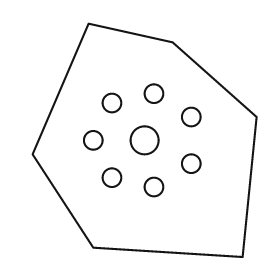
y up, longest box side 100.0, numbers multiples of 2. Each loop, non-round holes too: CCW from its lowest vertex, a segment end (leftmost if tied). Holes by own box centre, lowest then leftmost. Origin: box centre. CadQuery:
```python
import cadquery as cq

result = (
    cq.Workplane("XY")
    .moveTo(42.0, -50.0)
    .lineTo(48.0, 10.0)
    .lineTo(12.0, 42.0)
    .lineTo(-24.0, 50.0)
    .lineTo(-48.0, -6.0)
    .lineTo(-22.0, -46.0)
    .close()
    .moveTo(4.0, -20.0)
    .circle(4.0)
    .moveTo(-14.0, -16.0)
    .circle(4.0)
    .moveTo(20.0, -10.0)
    .circle(4.0)
    .moveTo(-22.0, 0.0)
    .circle(4.0)
    .moveTo(0.0, 0.0)
    .circle(6.0)
    .moveTo(20.0, 10.0)
    .circle(4.0)
    .moveTo(-14.0, 16.0)
    .circle(4.0)
    .moveTo(4.0, 20.0)
    .circle(4.0)
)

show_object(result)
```